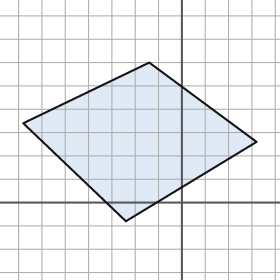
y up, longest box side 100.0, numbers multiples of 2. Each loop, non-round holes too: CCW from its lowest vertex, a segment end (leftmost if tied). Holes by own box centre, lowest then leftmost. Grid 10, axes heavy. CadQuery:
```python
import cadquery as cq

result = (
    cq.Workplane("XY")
    .moveTo(-24.0, -8.0)
    .lineTo(32.0, 26.0)
    .lineTo(-14.0, 60.0)
    .lineTo(-68.0, 34.0)
    .close()
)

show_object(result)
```